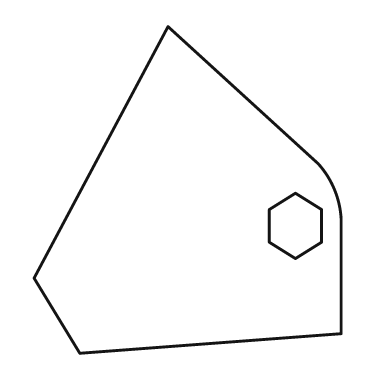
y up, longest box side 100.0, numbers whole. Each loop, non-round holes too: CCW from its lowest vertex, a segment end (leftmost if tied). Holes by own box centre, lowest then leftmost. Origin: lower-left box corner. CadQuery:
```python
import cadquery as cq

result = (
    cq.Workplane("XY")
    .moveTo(14.0, 0.0)
    .lineTo(94.0, 6.0)
    .lineTo(94.0, 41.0)
    .threePointArc((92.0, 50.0), (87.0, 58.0))
    .lineTo(41.0, 100.0)
    .lineTo(0.0, 23.0)
    .close()
    .moveTo(80.0, 29.0)
    .lineTo(88.0, 34.0)
    .lineTo(88.0, 44.0)
    .lineTo(80.0, 49.0)
    .lineTo(72.0, 44.0)
    .lineTo(72.0, 34.0)
    .close()
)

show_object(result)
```